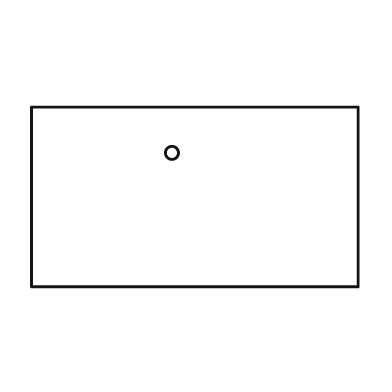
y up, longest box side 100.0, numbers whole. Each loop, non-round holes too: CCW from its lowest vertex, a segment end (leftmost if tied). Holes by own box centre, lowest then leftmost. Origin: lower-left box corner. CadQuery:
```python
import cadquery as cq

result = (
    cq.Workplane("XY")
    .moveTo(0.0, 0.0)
    .lineTo(100.0, 0.0)
    .lineTo(100.0, 55.0)
    .lineTo(0.0, 55.0)
    .close()
    .moveTo(43.0, 41.0)
    .circle(2.0)
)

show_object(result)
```